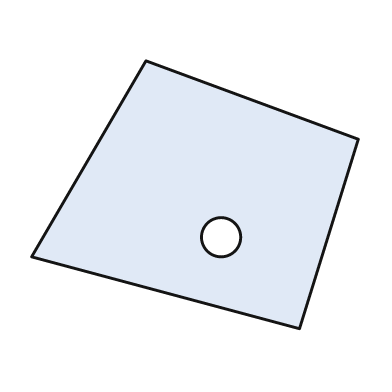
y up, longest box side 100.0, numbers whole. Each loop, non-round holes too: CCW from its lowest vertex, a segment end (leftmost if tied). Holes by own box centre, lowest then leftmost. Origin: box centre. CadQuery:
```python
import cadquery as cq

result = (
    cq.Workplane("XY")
    .moveTo(32.0, -41.0)
    .lineTo(50.0, 17.0)
    .lineTo(-15.0, 41.0)
    .lineTo(-50.0, -19.0)
    .close()
    .moveTo(8.0, -13.0)
    .circle(6.0)
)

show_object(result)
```